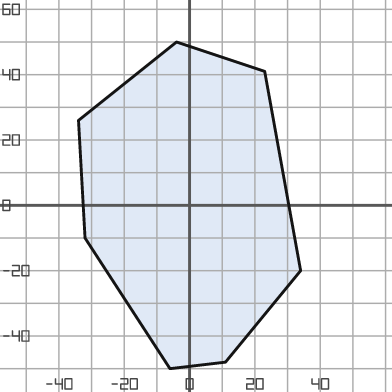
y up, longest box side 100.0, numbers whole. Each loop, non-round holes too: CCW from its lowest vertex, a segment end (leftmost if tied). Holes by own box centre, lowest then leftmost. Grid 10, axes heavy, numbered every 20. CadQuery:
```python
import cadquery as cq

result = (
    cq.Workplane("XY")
    .moveTo(-6.0, -50.0)
    .lineTo(11.0, -48.0)
    .lineTo(34.0, -20.0)
    .lineTo(23.0, 41.0)
    .lineTo(-4.0, 50.0)
    .lineTo(-34.0, 26.0)
    .lineTo(-32.0, -10.0)
    .close()
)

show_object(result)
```